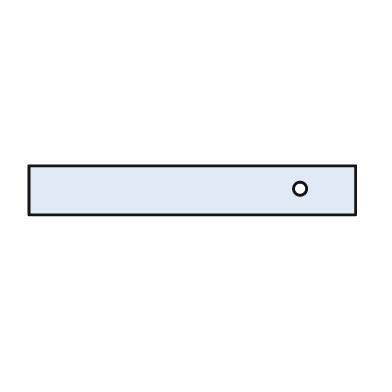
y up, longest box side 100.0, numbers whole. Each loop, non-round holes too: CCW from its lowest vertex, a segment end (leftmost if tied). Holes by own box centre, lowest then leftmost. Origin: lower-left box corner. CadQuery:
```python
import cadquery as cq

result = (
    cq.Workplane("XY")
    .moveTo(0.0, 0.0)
    .lineTo(100.0, 0.0)
    .lineTo(100.0, 15.0)
    .lineTo(0.0, 15.0)
    .close()
    .moveTo(83.0, 8.0)
    .circle(2.0)
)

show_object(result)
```